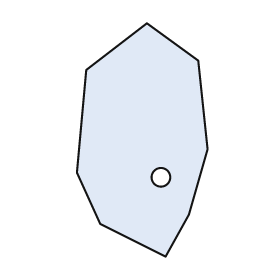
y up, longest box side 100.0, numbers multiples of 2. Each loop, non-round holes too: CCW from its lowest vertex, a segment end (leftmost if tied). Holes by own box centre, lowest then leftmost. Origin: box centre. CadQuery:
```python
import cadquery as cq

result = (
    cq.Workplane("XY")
    .moveTo(10.0, -50.0)
    .lineTo(20.0, -32.0)
    .lineTo(28.0, -4.0)
    .lineTo(24.0, 34.0)
    .lineTo(2.0, 50.0)
    .lineTo(-24.0, 30.0)
    .lineTo(-28.0, -14.0)
    .lineTo(-18.0, -36.0)
    .close()
    .moveTo(8.0, -16.0)
    .circle(4.0)
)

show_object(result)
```